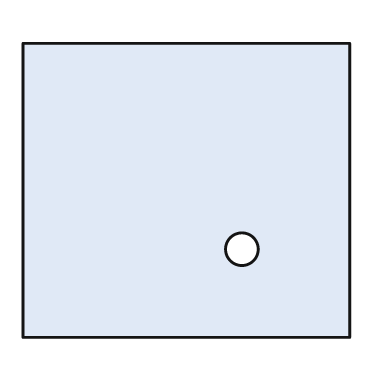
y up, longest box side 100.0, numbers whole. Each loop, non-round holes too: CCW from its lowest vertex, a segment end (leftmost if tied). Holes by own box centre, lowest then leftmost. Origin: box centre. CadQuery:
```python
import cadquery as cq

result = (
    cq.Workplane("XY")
    .moveTo(-50.0, -45.0)
    .lineTo(50.0, -45.0)
    .lineTo(50.0, 45.0)
    .lineTo(-50.0, 45.0)
    .close()
    .moveTo(17.0, -18.0)
    .circle(5.0)
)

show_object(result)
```